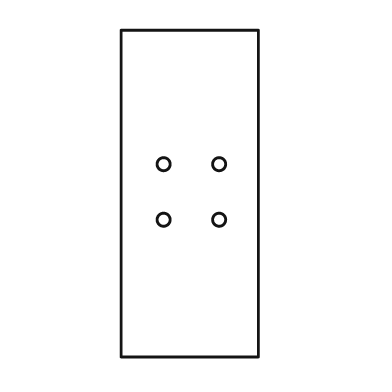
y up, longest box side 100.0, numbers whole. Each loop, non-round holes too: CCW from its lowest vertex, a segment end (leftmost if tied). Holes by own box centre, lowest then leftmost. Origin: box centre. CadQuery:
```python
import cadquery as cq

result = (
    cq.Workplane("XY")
    .moveTo(-21.0, -50.0)
    .lineTo(21.0, -50.0)
    .lineTo(21.0, 50.0)
    .lineTo(-21.0, 50.0)
    .close()
    .moveTo(-8.0, -8.0)
    .circle(2.0)
    .moveTo(9.0, -8.0)
    .circle(2.0)
    .moveTo(-8.0, 9.0)
    .circle(2.0)
    .moveTo(9.0, 9.0)
    .circle(2.0)
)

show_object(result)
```